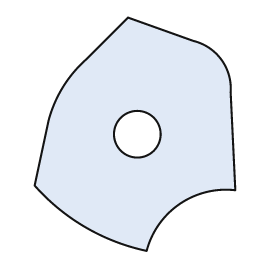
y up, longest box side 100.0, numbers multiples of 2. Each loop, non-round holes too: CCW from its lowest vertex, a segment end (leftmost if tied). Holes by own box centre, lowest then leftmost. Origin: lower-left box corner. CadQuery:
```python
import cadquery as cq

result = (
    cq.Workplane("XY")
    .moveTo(48.0, 0.0)
    .threePointArc((62.0, 20.0), (86.0, 26.0))
    .lineTo(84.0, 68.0)
    .threePointArc((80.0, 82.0), (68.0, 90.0))
    .lineTo(40.0, 100.0)
    .lineTo(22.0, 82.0)
    .threePointArc((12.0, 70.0), (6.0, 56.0))
    .lineTo(0.0, 28.0)
    .threePointArc((22.0, 10.0), (48.0, 0.0))
    .close()
    .moveTo(44.0, 50.0)
    .circle(10.0)
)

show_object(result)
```